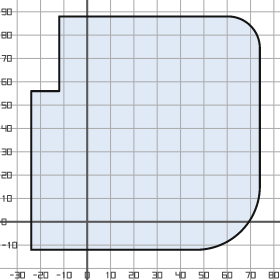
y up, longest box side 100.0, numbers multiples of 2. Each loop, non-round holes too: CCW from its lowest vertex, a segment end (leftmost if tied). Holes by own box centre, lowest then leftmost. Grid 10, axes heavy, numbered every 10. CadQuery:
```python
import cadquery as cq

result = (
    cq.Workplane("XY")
    .moveTo(-24.0, -12.0)
    .lineTo(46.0, -12.0)
    .threePointArc((66.0, -4.0), (74.0, 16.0))
    .lineTo(74.0, 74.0)
    .threePointArc((70.0, 84.0), (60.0, 88.0))
    .lineTo(-12.0, 88.0)
    .lineTo(-12.0, 56.0)
    .lineTo(-24.0, 56.0)
    .close()
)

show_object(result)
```